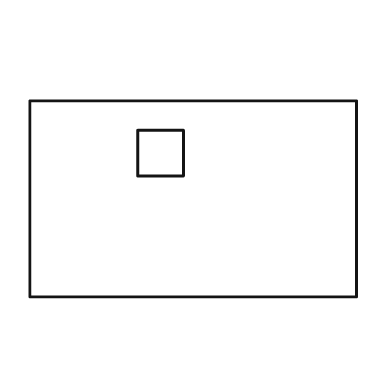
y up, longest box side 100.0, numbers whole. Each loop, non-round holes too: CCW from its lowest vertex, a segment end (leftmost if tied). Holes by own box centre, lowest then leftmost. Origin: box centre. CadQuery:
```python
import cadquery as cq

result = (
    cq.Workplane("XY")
    .moveTo(-50.0, -30.0)
    .lineTo(50.0, -30.0)
    .lineTo(50.0, 30.0)
    .lineTo(-50.0, 30.0)
    .close()
    .moveTo(-17.0, 7.0)
    .lineTo(-3.0, 7.0)
    .lineTo(-3.0, 21.0)
    .lineTo(-17.0, 21.0)
    .close()
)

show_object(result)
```